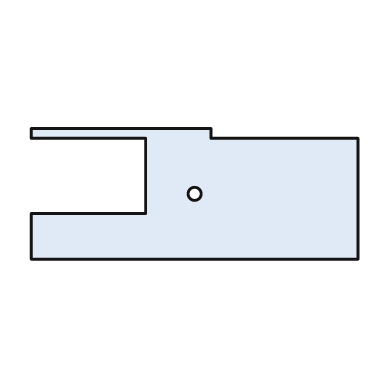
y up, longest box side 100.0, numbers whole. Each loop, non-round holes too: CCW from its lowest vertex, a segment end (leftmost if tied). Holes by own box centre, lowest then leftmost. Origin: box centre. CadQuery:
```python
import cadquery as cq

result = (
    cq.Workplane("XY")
    .moveTo(-50.0, -20.0)
    .lineTo(50.0, -20.0)
    .lineTo(50.0, 17.0)
    .lineTo(5.0, 17.0)
    .lineTo(5.0, 20.0)
    .lineTo(-50.0, 20.0)
    .lineTo(-50.0, 17.0)
    .lineTo(-15.0, 17.0)
    .lineTo(-15.0, -6.0)
    .lineTo(-50.0, -6.0)
    .close()
    .moveTo(0.0, 0.0)
    .circle(2.0)
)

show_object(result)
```